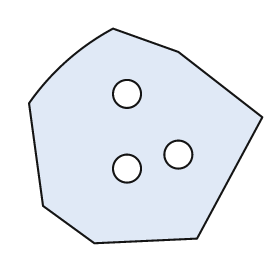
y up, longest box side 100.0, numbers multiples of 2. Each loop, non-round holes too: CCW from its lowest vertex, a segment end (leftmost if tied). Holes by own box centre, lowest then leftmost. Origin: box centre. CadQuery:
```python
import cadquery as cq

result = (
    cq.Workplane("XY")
    .moveTo(-22.0, -46.0)
    .lineTo(22.0, -44.0)
    .lineTo(50.0, 8.0)
    .lineTo(14.0, 36.0)
    .lineTo(-14.0, 46.0)
    .threePointArc((-34.0, 32.0), (-50.0, 14.0))
    .lineTo(-44.0, -30.0)
    .close()
    .moveTo(-8.0, -14.0)
    .circle(6.0)
    .moveTo(14.0, -8.0)
    .circle(6.0)
    .moveTo(-8.0, 18.0)
    .circle(6.0)
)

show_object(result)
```